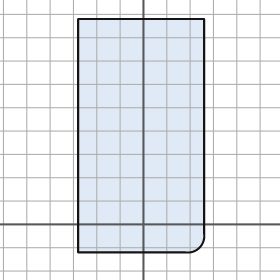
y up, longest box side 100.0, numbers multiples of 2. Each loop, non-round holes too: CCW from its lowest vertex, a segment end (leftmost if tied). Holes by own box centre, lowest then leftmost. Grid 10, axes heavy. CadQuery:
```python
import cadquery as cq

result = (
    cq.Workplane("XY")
    .moveTo(-28.0, -12.0)
    .lineTo(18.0, -12.0)
    .threePointArc((24.0, -10.0), (26.0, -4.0))
    .lineTo(26.0, 88.0)
    .lineTo(-28.0, 88.0)
    .close()
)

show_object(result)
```